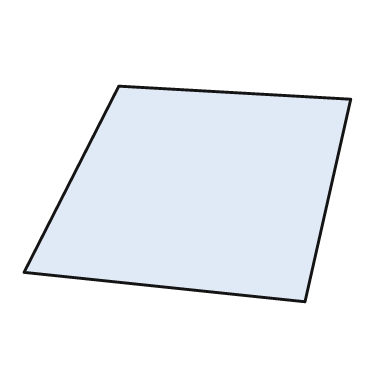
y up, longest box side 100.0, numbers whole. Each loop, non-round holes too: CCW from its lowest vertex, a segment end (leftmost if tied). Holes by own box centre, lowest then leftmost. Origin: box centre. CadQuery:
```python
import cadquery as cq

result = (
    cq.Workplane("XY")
    .moveTo(36.0, -33.0)
    .lineTo(50.0, 29.0)
    .lineTo(-21.0, 33.0)
    .lineTo(-50.0, -24.0)
    .close()
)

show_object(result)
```